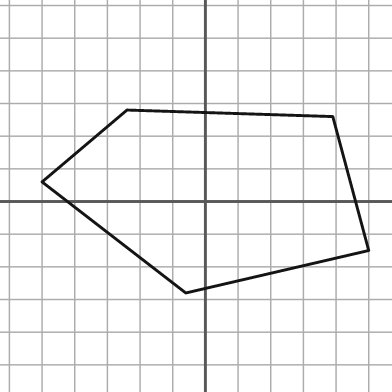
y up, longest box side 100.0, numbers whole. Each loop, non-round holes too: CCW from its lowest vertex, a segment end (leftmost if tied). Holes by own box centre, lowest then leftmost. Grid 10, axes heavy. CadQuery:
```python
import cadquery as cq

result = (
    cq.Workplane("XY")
    .moveTo(-6.0, -28.0)
    .lineTo(50.0, -15.0)
    .lineTo(39.0, 26.0)
    .lineTo(-24.0, 28.0)
    .lineTo(-50.0, 6.0)
    .close()
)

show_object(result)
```